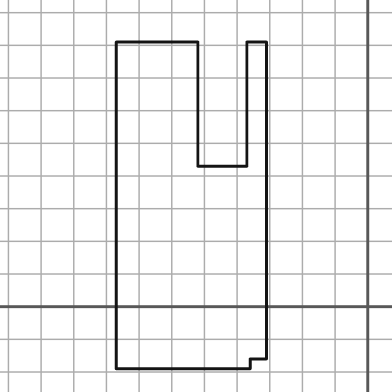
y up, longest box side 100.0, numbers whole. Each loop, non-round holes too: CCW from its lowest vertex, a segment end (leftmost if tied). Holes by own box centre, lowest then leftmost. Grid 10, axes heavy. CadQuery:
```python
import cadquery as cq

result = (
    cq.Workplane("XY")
    .moveTo(-77.0, -19.0)
    .lineTo(-36.0, -19.0)
    .lineTo(-36.0, -16.0)
    .lineTo(-31.0, -16.0)
    .lineTo(-31.0, 81.0)
    .lineTo(-37.0, 81.0)
    .lineTo(-37.0, 43.0)
    .lineTo(-52.0, 43.0)
    .lineTo(-52.0, 81.0)
    .lineTo(-77.0, 81.0)
    .close()
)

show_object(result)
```